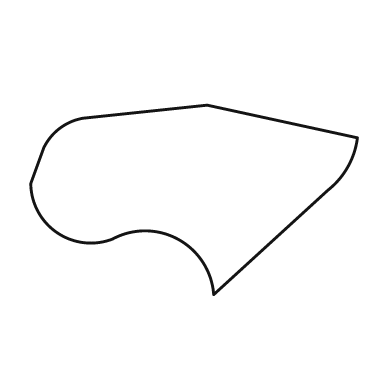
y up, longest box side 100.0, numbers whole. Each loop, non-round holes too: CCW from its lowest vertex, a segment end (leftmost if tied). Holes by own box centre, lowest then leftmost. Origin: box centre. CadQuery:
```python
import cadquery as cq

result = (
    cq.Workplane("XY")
    .moveTo(6.0, -29.0)
    .lineTo(41.0, 3.0)
    .threePointArc((47.0, 10.0), (50.0, 19.0))
    .lineTo(4.0, 29.0)
    .lineTo(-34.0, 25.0)
    .threePointArc((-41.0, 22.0), (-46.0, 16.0))
    .lineTo(-50.0, 5.0)
    .threePointArc((-42.0, -10.0), (-25.0, -12.0))
    .threePointArc((-5.0, -12.0), (6.0, -29.0))
    .close()
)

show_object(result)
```